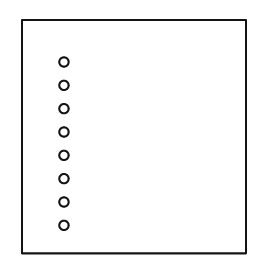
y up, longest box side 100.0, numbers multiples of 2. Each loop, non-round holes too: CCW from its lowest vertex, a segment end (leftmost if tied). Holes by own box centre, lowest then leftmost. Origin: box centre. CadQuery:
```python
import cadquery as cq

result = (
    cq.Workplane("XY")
    .moveTo(-48.0, -50.0)
    .lineTo(48.0, -50.0)
    .lineTo(48.0, 50.0)
    .lineTo(-48.0, 50.0)
    .close()
    .moveTo(-30.0, -38.0)
    .circle(2.0)
    .moveTo(-30.0, -28.0)
    .circle(2.0)
    .moveTo(-30.0, -18.0)
    .circle(2.0)
    .moveTo(-30.0, -8.0)
    .circle(2.0)
    .moveTo(-30.0, 2.0)
    .circle(2.0)
    .moveTo(-30.0, 12.0)
    .circle(2.0)
    .moveTo(-30.0, 22.0)
    .circle(2.0)
    .moveTo(-30.0, 32.0)
    .circle(2.0)
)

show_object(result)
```